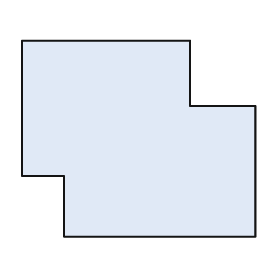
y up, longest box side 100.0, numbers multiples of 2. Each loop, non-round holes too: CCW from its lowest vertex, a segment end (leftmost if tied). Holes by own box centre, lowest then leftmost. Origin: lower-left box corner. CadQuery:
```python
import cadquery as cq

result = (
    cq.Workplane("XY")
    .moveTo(18.0, 0.0)
    .lineTo(100.0, 0.0)
    .lineTo(100.0, 56.0)
    .lineTo(72.0, 56.0)
    .lineTo(72.0, 84.0)
    .lineTo(0.0, 84.0)
    .lineTo(0.0, 26.0)
    .lineTo(18.0, 26.0)
    .close()
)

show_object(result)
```